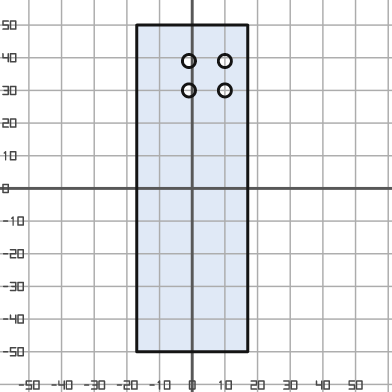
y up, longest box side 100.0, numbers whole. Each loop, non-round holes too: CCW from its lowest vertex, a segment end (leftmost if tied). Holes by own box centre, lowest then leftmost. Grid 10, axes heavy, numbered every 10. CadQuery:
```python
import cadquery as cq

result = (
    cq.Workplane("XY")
    .moveTo(-17.0, -50.0)
    .lineTo(17.0, -50.0)
    .lineTo(17.0, 50.0)
    .lineTo(-17.0, 50.0)
    .close()
    .moveTo(-1.0, 30.0)
    .circle(2.0)
    .moveTo(10.0, 30.0)
    .circle(2.0)
    .moveTo(-1.0, 39.0)
    .circle(2.0)
    .moveTo(10.0, 39.0)
    .circle(2.0)
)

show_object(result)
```